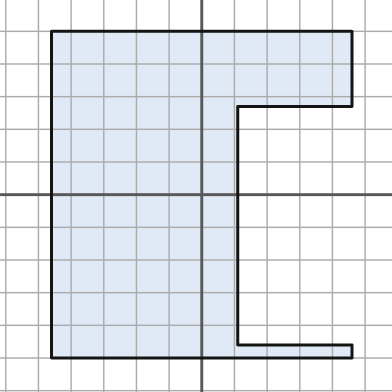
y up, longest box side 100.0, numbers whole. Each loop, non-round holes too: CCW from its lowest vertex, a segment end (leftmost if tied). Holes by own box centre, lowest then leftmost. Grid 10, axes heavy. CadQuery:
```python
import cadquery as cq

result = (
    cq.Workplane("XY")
    .moveTo(-46.0, -50.0)
    .lineTo(46.0, -50.0)
    .lineTo(46.0, -46.0)
    .lineTo(11.0, -46.0)
    .lineTo(11.0, 27.0)
    .lineTo(46.0, 27.0)
    .lineTo(46.0, 50.0)
    .lineTo(-46.0, 50.0)
    .close()
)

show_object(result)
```